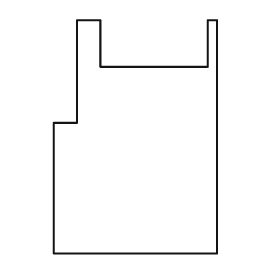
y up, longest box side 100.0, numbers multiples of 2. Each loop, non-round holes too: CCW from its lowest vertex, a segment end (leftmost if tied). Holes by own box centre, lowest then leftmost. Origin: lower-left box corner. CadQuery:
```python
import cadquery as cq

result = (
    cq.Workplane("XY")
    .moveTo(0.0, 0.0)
    .lineTo(70.0, 0.0)
    .lineTo(70.0, 100.0)
    .lineTo(66.0, 100.0)
    .lineTo(66.0, 80.0)
    .lineTo(20.0, 80.0)
    .lineTo(20.0, 100.0)
    .lineTo(10.0, 100.0)
    .lineTo(10.0, 56.0)
    .lineTo(0.0, 56.0)
    .close()
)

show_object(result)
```